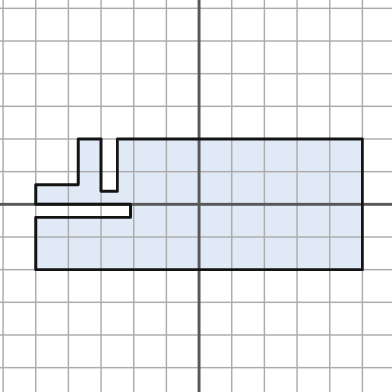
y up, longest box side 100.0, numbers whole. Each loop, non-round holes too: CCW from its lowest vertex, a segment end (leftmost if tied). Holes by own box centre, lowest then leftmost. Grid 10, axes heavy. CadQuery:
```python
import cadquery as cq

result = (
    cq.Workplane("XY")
    .moveTo(-50.0, -20.0)
    .lineTo(50.0, -20.0)
    .lineTo(50.0, 20.0)
    .lineTo(-25.0, 20.0)
    .lineTo(-25.0, 4.0)
    .lineTo(-30.0, 4.0)
    .lineTo(-30.0, 20.0)
    .lineTo(-37.0, 20.0)
    .lineTo(-37.0, 6.0)
    .lineTo(-50.0, 6.0)
    .lineTo(-50.0, 0.0)
    .lineTo(-21.0, 0.0)
    .lineTo(-21.0, -4.0)
    .lineTo(-50.0, -4.0)
    .close()
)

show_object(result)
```